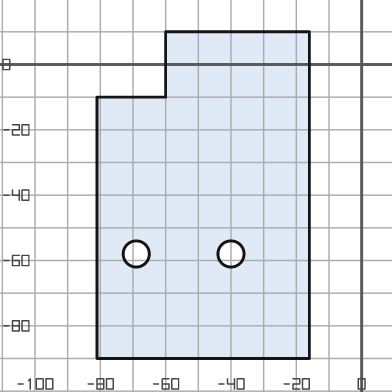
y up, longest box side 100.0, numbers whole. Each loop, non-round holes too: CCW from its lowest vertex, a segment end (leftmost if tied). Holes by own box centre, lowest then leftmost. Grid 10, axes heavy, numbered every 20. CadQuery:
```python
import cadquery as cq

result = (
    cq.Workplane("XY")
    .moveTo(-81.0, -90.0)
    .lineTo(-16.0, -90.0)
    .lineTo(-16.0, 10.0)
    .lineTo(-60.0, 10.0)
    .lineTo(-60.0, -10.0)
    .lineTo(-81.0, -10.0)
    .close()
    .moveTo(-69.0, -58.0)
    .circle(4.0)
    .moveTo(-40.0, -58.0)
    .circle(4.0)
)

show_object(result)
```